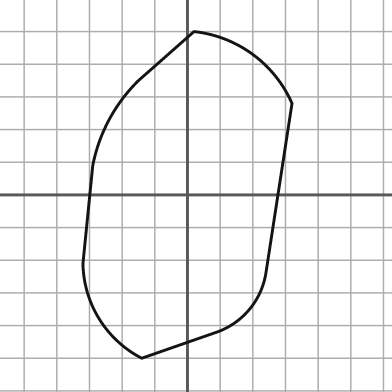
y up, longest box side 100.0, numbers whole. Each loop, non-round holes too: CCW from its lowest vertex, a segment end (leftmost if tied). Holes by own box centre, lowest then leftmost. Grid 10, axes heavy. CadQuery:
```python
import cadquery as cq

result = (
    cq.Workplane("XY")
    .moveTo(-14.0, -50.0)
    .lineTo(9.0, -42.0)
    .threePointArc((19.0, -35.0), (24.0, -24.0))
    .lineTo(32.0, 28.0)
    .threePointArc((20.0, 43.0), (2.0, 50.0))
    .lineTo(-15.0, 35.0)
    .threePointArc((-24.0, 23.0), (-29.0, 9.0))
    .lineTo(-32.0, -21.0)
    .threePointArc((-27.0, -38.0), (-14.0, -50.0))
    .close()
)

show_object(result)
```